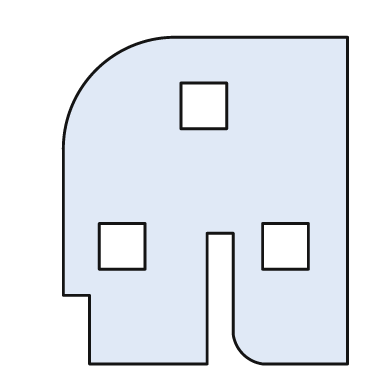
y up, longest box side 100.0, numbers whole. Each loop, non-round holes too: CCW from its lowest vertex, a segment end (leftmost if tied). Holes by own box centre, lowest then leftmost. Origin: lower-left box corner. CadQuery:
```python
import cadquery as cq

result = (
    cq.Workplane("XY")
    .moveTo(8.0, 0.0)
    .lineTo(44.0, 0.0)
    .lineTo(44.0, 40.0)
    .lineTo(52.0, 40.0)
    .lineTo(52.0, 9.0)
    .threePointArc((55.0, 3.0), (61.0, 0.0))
    .lineTo(87.0, 0.0)
    .lineTo(87.0, 100.0)
    .lineTo(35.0, 100.0)
    .threePointArc((10.0, 90.0), (0.0, 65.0))
    .lineTo(0.0, 21.0)
    .lineTo(8.0, 21.0)
    .close()
    .moveTo(11.0, 29.0)
    .lineTo(25.0, 29.0)
    .lineTo(25.0, 43.0)
    .lineTo(11.0, 43.0)
    .close()
    .moveTo(61.0, 29.0)
    .lineTo(75.0, 29.0)
    .lineTo(75.0, 43.0)
    .lineTo(61.0, 43.0)
    .close()
    .moveTo(36.0, 72.0)
    .lineTo(50.0, 72.0)
    .lineTo(50.0, 86.0)
    .lineTo(36.0, 86.0)
    .close()
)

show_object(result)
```